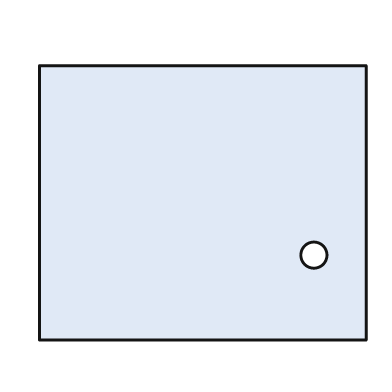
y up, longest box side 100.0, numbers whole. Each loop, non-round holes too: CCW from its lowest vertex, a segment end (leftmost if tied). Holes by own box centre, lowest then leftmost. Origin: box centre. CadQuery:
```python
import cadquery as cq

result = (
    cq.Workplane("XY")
    .moveTo(-50.0, -42.0)
    .lineTo(50.0, -42.0)
    .lineTo(50.0, 42.0)
    .lineTo(-50.0, 42.0)
    .close()
    .moveTo(34.0, -16.0)
    .circle(4.0)
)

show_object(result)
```